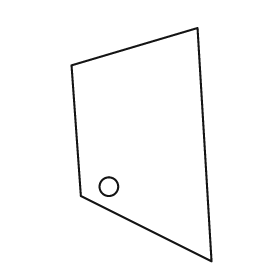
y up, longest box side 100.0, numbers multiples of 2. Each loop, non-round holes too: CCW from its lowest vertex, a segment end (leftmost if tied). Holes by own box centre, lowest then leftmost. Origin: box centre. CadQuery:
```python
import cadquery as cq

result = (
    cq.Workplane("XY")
    .moveTo(30.0, -50.0)
    .lineTo(24.0, 50.0)
    .lineTo(-30.0, 34.0)
    .lineTo(-26.0, -22.0)
    .close()
    .moveTo(-14.0, -18.0)
    .circle(4.0)
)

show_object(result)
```